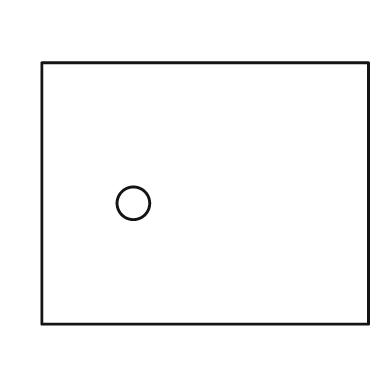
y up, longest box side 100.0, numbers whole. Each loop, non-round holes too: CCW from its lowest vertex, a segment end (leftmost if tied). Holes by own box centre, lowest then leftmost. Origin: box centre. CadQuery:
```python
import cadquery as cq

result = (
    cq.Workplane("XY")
    .moveTo(-50.0, -40.0)
    .lineTo(50.0, -40.0)
    .lineTo(50.0, 40.0)
    .lineTo(-50.0, 40.0)
    .close()
    .moveTo(-22.0, -3.0)
    .circle(5.0)
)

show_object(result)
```